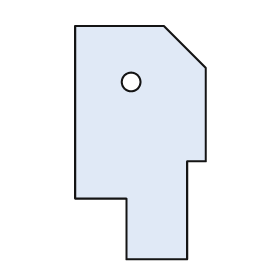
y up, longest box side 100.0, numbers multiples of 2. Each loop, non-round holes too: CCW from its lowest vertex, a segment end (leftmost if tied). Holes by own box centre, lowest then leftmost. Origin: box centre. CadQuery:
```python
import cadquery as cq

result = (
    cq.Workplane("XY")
    .moveTo(-6.0, -50.0)
    .lineTo(20.0, -50.0)
    .lineTo(20.0, -8.0)
    .lineTo(28.0, -8.0)
    .lineTo(28.0, 32.0)
    .lineTo(10.0, 50.0)
    .lineTo(-28.0, 50.0)
    .lineTo(-28.0, -24.0)
    .lineTo(-6.0, -24.0)
    .close()
    .moveTo(-4.0, 26.0)
    .circle(4.0)
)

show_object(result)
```